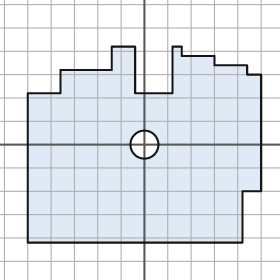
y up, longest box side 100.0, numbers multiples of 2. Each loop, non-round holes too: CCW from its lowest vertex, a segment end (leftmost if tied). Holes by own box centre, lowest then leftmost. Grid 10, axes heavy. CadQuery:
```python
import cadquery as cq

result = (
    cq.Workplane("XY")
    .moveTo(-50.0, -42.0)
    .lineTo(42.0, -42.0)
    .lineTo(42.0, -20.0)
    .lineTo(50.0, -20.0)
    .lineTo(50.0, 30.0)
    .lineTo(44.0, 30.0)
    .lineTo(44.0, 34.0)
    .lineTo(30.0, 34.0)
    .lineTo(30.0, 38.0)
    .lineTo(16.0, 38.0)
    .lineTo(16.0, 42.0)
    .lineTo(12.0, 42.0)
    .lineTo(12.0, 22.0)
    .lineTo(-4.0, 22.0)
    .lineTo(-4.0, 42.0)
    .lineTo(-14.0, 42.0)
    .lineTo(-14.0, 32.0)
    .lineTo(-36.0, 32.0)
    .lineTo(-36.0, 22.0)
    .lineTo(-50.0, 22.0)
    .close()
    .moveTo(0.0, 0.0)
    .circle(6.0)
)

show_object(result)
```